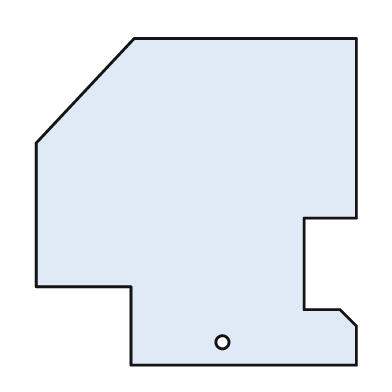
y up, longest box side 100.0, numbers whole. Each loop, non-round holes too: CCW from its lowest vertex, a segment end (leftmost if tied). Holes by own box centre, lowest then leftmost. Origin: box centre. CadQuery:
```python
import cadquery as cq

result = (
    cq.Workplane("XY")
    .moveTo(-20.0, -50.0)
    .lineTo(49.0, -50.0)
    .lineTo(49.0, -38.0)
    .lineTo(44.0, -33.0)
    .lineTo(33.0, -33.0)
    .lineTo(33.0, -5.0)
    .lineTo(49.0, -5.0)
    .lineTo(49.0, 50.0)
    .lineTo(-19.0, 50.0)
    .lineTo(-49.0, 18.0)
    .lineTo(-49.0, -26.0)
    .lineTo(-20.0, -26.0)
    .close()
    .moveTo(8.0, -43.0)
    .circle(2.0)
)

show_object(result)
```